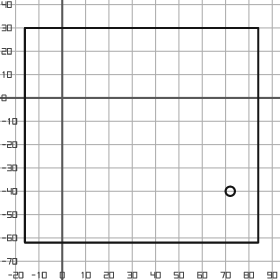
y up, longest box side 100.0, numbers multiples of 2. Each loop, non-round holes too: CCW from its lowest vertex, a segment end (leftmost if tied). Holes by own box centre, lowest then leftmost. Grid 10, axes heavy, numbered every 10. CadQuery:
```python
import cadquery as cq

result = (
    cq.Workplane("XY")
    .moveTo(-16.0, -62.0)
    .lineTo(84.0, -62.0)
    .lineTo(84.0, 30.0)
    .lineTo(-16.0, 30.0)
    .close()
    .moveTo(72.0, -40.0)
    .circle(2.0)
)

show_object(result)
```